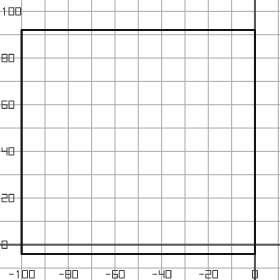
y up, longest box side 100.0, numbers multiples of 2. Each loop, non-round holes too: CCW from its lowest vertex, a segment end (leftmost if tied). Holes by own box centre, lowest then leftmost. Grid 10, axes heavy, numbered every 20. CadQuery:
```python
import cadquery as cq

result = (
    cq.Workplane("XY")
    .moveTo(-100.0, -4.0)
    .lineTo(0.0, -4.0)
    .lineTo(0.0, 92.0)
    .lineTo(-100.0, 92.0)
    .close()
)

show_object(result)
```